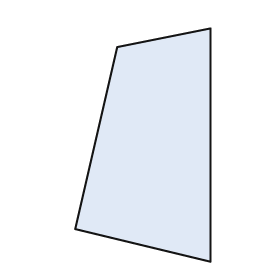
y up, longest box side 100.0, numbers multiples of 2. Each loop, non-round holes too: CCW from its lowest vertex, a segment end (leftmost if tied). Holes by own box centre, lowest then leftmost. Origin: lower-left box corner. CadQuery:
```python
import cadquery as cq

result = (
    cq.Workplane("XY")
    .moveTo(58.0, 0.0)
    .lineTo(58.0, 100.0)
    .lineTo(18.0, 92.0)
    .lineTo(0.0, 14.0)
    .close()
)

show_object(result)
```